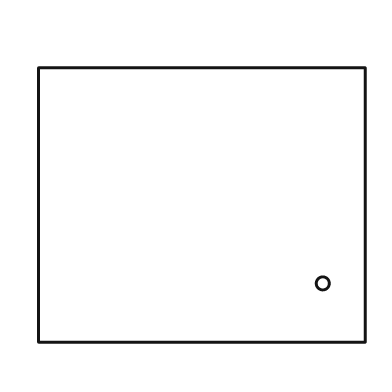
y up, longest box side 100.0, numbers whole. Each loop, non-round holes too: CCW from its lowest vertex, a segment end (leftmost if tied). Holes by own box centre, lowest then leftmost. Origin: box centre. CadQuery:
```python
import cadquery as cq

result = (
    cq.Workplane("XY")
    .moveTo(-50.0, -42.0)
    .lineTo(50.0, -42.0)
    .lineTo(50.0, 42.0)
    .lineTo(-50.0, 42.0)
    .close()
    .moveTo(37.0, -24.0)
    .circle(2.0)
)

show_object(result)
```